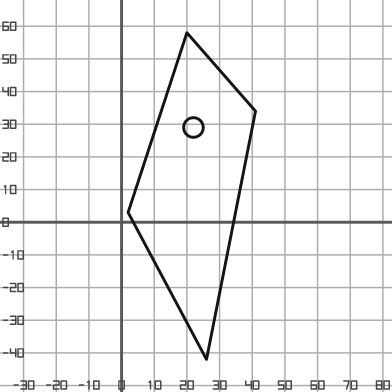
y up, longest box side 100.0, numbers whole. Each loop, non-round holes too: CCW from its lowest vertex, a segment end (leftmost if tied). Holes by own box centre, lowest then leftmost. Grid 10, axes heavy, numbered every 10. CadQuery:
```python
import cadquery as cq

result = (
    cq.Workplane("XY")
    .moveTo(26.0, -42.0)
    .lineTo(41.0, 34.0)
    .lineTo(20.0, 58.0)
    .lineTo(2.0, 3.0)
    .close()
    .moveTo(22.0, 29.0)
    .circle(3.0)
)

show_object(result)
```